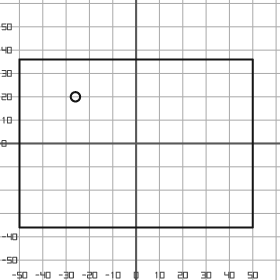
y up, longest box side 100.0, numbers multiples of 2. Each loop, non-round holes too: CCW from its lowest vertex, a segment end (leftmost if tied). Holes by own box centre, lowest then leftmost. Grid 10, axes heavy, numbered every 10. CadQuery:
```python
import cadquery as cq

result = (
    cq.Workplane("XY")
    .moveTo(-50.0, -36.0)
    .lineTo(50.0, -36.0)
    .lineTo(50.0, 36.0)
    .lineTo(-50.0, 36.0)
    .close()
    .moveTo(-26.0, 20.0)
    .circle(2.0)
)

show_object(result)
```